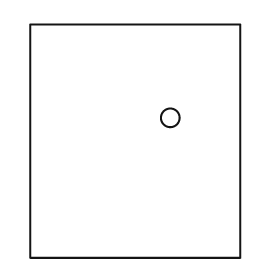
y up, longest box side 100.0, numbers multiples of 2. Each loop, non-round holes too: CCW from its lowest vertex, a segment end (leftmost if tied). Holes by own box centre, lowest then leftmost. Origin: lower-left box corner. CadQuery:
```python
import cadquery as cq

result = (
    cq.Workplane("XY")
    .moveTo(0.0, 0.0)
    .lineTo(90.0, 0.0)
    .lineTo(90.0, 100.0)
    .lineTo(0.0, 100.0)
    .close()
    .moveTo(60.0, 60.0)
    .circle(4.0)
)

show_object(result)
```